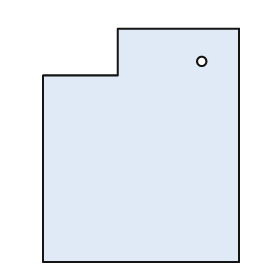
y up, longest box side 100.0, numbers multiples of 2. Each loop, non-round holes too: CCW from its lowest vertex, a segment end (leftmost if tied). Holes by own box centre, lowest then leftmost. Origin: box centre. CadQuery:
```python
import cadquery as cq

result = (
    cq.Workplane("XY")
    .moveTo(-42.0, -50.0)
    .lineTo(42.0, -50.0)
    .lineTo(42.0, 50.0)
    .lineTo(-10.0, 50.0)
    .lineTo(-10.0, 30.0)
    .lineTo(-42.0, 30.0)
    .close()
    .moveTo(26.0, 36.0)
    .circle(2.0)
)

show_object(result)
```